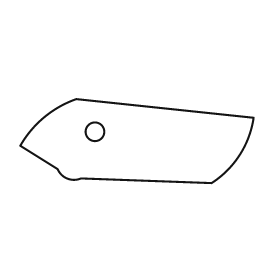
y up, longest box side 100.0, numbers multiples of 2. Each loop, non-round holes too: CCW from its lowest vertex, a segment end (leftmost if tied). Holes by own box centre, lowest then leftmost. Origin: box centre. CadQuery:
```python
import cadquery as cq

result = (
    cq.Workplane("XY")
    .moveTo(32.0, -18.0)
    .threePointArc((44.0, -6.0), (50.0, 10.0))
    .lineTo(-26.0, 18.0)
    .threePointArc((-40.0, 10.0), (-50.0, -2.0))
    .lineTo(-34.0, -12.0)
    .threePointArc((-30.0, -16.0), (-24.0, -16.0))
    .close()
    .moveTo(-18.0, 4.0)
    .circle(4.0)
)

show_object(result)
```